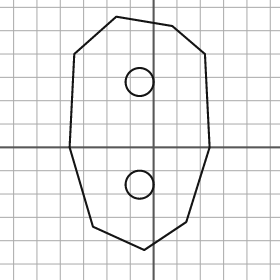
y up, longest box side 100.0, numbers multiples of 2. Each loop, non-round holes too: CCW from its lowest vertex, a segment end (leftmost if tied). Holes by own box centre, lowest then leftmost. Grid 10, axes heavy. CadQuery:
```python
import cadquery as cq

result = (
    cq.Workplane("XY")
    .moveTo(-4.0, -44.0)
    .lineTo(14.0, -32.0)
    .lineTo(24.0, 0.0)
    .lineTo(22.0, 40.0)
    .lineTo(8.0, 52.0)
    .lineTo(-16.0, 56.0)
    .lineTo(-34.0, 40.0)
    .lineTo(-36.0, 0.0)
    .lineTo(-26.0, -34.0)
    .close()
    .moveTo(-6.0, -16.0)
    .circle(6.0)
    .moveTo(-6.0, 28.0)
    .circle(6.0)
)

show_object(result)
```